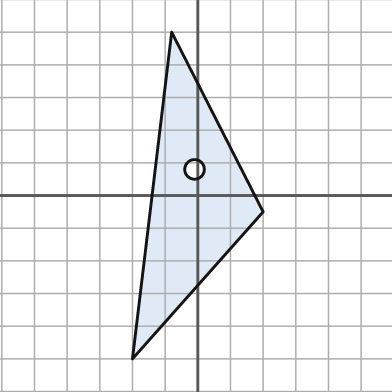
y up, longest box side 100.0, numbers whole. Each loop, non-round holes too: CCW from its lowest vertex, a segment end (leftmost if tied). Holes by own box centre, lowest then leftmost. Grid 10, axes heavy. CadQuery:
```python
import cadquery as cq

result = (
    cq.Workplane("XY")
    .moveTo(-20.0, -50.0)
    .lineTo(20.0, -5.0)
    .lineTo(-8.0, 50.0)
    .close()
    .moveTo(-1.0, 8.0)
    .circle(3.0)
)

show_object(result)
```